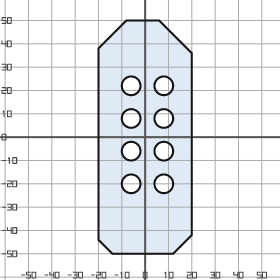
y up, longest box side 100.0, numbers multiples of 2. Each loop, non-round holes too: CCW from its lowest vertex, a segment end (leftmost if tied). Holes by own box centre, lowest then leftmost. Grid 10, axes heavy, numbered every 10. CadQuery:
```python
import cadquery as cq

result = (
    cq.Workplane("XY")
    .moveTo(-14.0, -50.0)
    .lineTo(12.0, -50.0)
    .lineTo(20.0, -42.0)
    .lineTo(20.0, 36.0)
    .lineTo(6.0, 50.0)
    .lineTo(-8.0, 50.0)
    .lineTo(-20.0, 38.0)
    .lineTo(-20.0, -44.0)
    .close()
    .moveTo(-6.0, -20.0)
    .circle(4.0)
    .moveTo(8.0, -20.0)
    .circle(4.0)
    .moveTo(-6.0, -6.0)
    .circle(4.0)
    .moveTo(8.0, -6.0)
    .circle(4.0)
    .moveTo(-6.0, 8.0)
    .circle(4.0)
    .moveTo(8.0, 8.0)
    .circle(4.0)
    .moveTo(-6.0, 22.0)
    .circle(4.0)
    .moveTo(8.0, 22.0)
    .circle(4.0)
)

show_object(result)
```